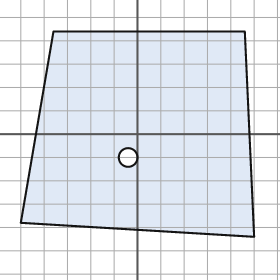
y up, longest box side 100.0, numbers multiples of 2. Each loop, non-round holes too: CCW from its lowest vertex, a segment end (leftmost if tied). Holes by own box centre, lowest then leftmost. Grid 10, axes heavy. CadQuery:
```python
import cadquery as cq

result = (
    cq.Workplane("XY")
    .moveTo(50.0, -44.0)
    .lineTo(46.0, 44.0)
    .lineTo(-36.0, 44.0)
    .lineTo(-50.0, -38.0)
    .close()
    .moveTo(-4.0, -10.0)
    .circle(4.0)
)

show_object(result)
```